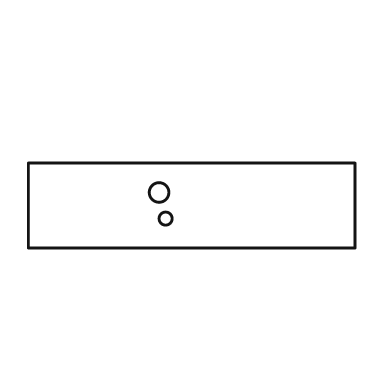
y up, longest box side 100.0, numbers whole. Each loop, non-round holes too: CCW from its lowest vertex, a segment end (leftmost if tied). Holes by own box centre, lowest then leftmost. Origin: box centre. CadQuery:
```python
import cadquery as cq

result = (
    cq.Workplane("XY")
    .moveTo(-50.0, -13.0)
    .lineTo(50.0, -13.0)
    .lineTo(50.0, 13.0)
    .lineTo(-50.0, 13.0)
    .close()
    .moveTo(-8.0, -4.0)
    .circle(2.0)
    .moveTo(-10.0, 4.0)
    .circle(3.0)
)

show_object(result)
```